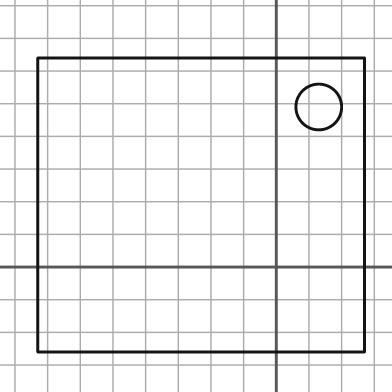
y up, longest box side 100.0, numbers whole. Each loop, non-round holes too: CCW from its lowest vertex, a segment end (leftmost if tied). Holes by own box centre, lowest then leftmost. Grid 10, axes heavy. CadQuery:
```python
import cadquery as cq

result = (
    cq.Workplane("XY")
    .moveTo(-73.0, -26.0)
    .lineTo(27.0, -26.0)
    .lineTo(27.0, 64.0)
    .lineTo(-73.0, 64.0)
    .close()
    .moveTo(13.0, 49.0)
    .circle(7.0)
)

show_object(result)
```